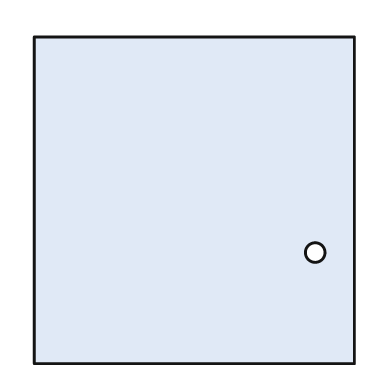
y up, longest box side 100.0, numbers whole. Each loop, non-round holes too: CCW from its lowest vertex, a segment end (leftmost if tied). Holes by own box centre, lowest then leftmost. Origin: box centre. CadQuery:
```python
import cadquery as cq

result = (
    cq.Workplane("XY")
    .moveTo(-49.0, -50.0)
    .lineTo(49.0, -50.0)
    .lineTo(49.0, 50.0)
    .lineTo(-49.0, 50.0)
    .close()
    .moveTo(37.0, -16.0)
    .circle(3.0)
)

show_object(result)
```